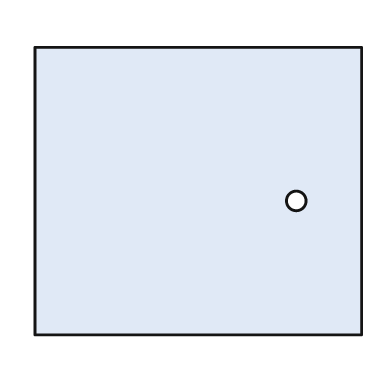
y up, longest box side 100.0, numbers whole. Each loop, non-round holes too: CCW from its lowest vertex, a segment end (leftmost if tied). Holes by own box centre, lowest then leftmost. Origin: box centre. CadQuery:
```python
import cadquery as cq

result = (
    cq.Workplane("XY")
    .moveTo(-50.0, -44.0)
    .lineTo(50.0, -44.0)
    .lineTo(50.0, 44.0)
    .lineTo(-50.0, 44.0)
    .close()
    .moveTo(30.0, -3.0)
    .circle(3.0)
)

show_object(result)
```